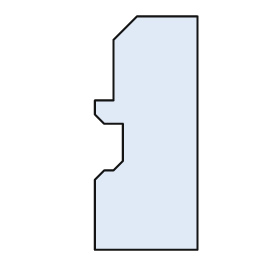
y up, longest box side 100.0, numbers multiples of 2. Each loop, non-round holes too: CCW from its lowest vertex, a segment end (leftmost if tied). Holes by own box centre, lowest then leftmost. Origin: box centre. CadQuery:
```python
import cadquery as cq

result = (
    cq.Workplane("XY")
    .moveTo(-22.0, -50.0)
    .lineTo(22.0, -50.0)
    .lineTo(22.0, 50.0)
    .lineTo(-4.0, 50.0)
    .lineTo(-14.0, 40.0)
    .lineTo(-14.0, 14.0)
    .lineTo(-22.0, 14.0)
    .lineTo(-22.0, 8.0)
    .lineTo(-18.0, 4.0)
    .lineTo(-10.0, 4.0)
    .lineTo(-10.0, -12.0)
    .lineTo(-14.0, -16.0)
    .lineTo(-18.0, -16.0)
    .lineTo(-22.0, -20.0)
    .close()
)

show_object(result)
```